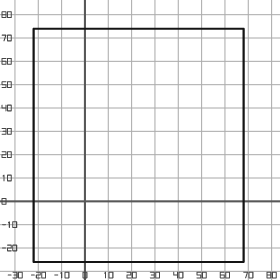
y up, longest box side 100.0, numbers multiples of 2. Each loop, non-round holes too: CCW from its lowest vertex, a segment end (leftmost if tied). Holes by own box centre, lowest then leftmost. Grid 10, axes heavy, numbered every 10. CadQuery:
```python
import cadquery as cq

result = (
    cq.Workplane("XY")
    .moveTo(-22.0, -26.0)
    .lineTo(68.0, -26.0)
    .lineTo(68.0, 74.0)
    .lineTo(-22.0, 74.0)
    .close()
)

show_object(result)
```